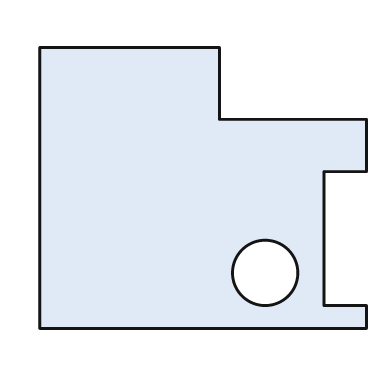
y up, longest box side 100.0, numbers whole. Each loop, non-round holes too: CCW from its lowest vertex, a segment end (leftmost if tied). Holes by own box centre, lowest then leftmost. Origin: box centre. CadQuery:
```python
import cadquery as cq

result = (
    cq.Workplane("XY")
    .moveTo(-50.0, -43.0)
    .lineTo(50.0, -43.0)
    .lineTo(50.0, -36.0)
    .lineTo(37.0, -36.0)
    .lineTo(37.0, 5.0)
    .lineTo(50.0, 5.0)
    .lineTo(50.0, 21.0)
    .lineTo(5.0, 21.0)
    .lineTo(5.0, 43.0)
    .lineTo(-50.0, 43.0)
    .close()
    .moveTo(19.0, -26.0)
    .circle(10.0)
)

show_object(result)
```